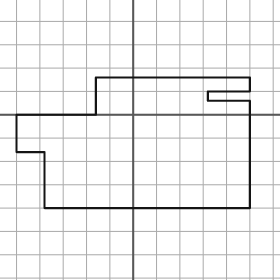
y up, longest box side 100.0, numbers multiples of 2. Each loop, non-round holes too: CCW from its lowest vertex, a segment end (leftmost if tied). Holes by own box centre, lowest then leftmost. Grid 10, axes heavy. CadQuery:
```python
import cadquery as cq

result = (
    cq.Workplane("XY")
    .moveTo(-38.0, -40.0)
    .lineTo(50.0, -40.0)
    .lineTo(50.0, 6.0)
    .lineTo(32.0, 6.0)
    .lineTo(32.0, 10.0)
    .lineTo(50.0, 10.0)
    .lineTo(50.0, 16.0)
    .lineTo(-16.0, 16.0)
    .lineTo(-16.0, 0.0)
    .lineTo(-50.0, 0.0)
    .lineTo(-50.0, -16.0)
    .lineTo(-38.0, -16.0)
    .close()
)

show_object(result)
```